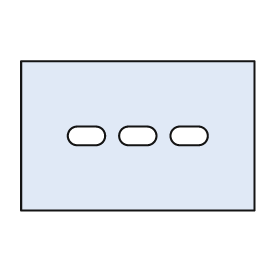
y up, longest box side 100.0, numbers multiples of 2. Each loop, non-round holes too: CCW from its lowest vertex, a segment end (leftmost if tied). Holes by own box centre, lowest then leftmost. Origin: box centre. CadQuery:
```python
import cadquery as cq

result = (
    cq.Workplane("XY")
    .moveTo(-50.0, -32.0)
    .lineTo(50.0, -32.0)
    .lineTo(50.0, 32.0)
    .lineTo(-50.0, 32.0)
    .close()
    .moveTo(-26.0, -4.0)
    .lineTo(-18.0, -4.0)
    .threePointArc((-14.0, 0.0), (-18.0, 4.0))
    .lineTo(-26.0, 4.0)
    .threePointArc((-30.0, 0.0), (-26.0, -4.0))
    .close()
    .moveTo(-4.0, -4.0)
    .lineTo(4.0, -4.0)
    .threePointArc((8.0, 0.0), (4.0, 4.0))
    .lineTo(-4.0, 4.0)
    .threePointArc((-8.0, 0.0), (-4.0, -4.0))
    .close()
    .moveTo(18.0, -4.0)
    .lineTo(26.0, -4.0)
    .threePointArc((30.0, 0.0), (26.0, 4.0))
    .lineTo(18.0, 4.0)
    .threePointArc((14.0, 0.0), (18.0, -4.0))
    .close()
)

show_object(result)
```